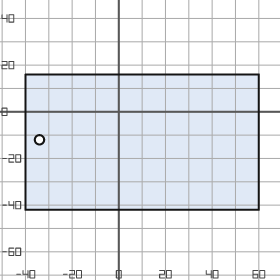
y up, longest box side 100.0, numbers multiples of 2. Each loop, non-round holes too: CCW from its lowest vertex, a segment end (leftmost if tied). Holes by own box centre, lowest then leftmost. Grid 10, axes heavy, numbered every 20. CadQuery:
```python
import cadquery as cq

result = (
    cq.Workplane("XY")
    .moveTo(-40.0, -42.0)
    .lineTo(60.0, -42.0)
    .lineTo(60.0, 16.0)
    .lineTo(-40.0, 16.0)
    .close()
    .moveTo(-34.0, -12.0)
    .circle(2.0)
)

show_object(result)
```